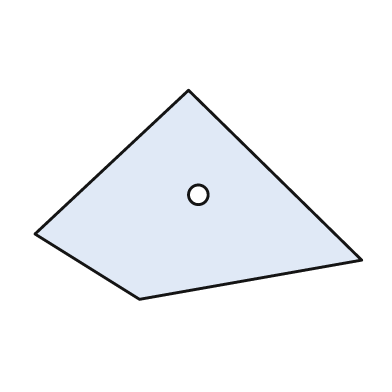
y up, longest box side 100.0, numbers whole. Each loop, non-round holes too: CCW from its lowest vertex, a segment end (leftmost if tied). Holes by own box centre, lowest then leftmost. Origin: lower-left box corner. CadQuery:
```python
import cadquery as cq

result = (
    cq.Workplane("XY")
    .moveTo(32.0, 0.0)
    .lineTo(100.0, 12.0)
    .lineTo(47.0, 64.0)
    .lineTo(0.0, 20.0)
    .close()
    .moveTo(50.0, 32.0)
    .circle(3.0)
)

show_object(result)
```